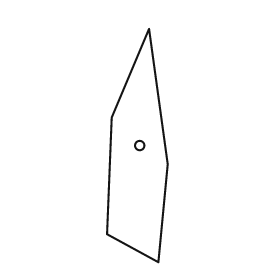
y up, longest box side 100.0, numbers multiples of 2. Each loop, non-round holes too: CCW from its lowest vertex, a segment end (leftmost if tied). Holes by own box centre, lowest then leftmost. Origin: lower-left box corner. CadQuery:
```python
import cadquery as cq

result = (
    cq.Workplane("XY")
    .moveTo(22.0, 0.0)
    .lineTo(26.0, 42.0)
    .lineTo(18.0, 100.0)
    .lineTo(2.0, 62.0)
    .lineTo(0.0, 12.0)
    .close()
    .moveTo(14.0, 50.0)
    .circle(2.0)
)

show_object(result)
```